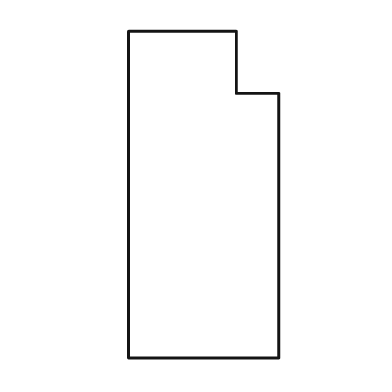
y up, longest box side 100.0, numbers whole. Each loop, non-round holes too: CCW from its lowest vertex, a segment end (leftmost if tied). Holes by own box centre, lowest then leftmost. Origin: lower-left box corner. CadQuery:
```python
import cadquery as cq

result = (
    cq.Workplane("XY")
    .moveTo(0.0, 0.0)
    .lineTo(46.0, 0.0)
    .lineTo(46.0, 81.0)
    .lineTo(33.0, 81.0)
    .lineTo(33.0, 100.0)
    .lineTo(0.0, 100.0)
    .close()
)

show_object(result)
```